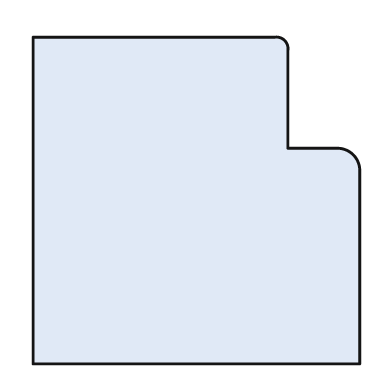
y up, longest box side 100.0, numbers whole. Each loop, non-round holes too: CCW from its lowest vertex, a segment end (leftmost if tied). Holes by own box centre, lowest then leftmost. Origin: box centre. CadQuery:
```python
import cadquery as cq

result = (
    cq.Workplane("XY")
    .moveTo(-50.0, -50.0)
    .lineTo(50.0, -50.0)
    .lineTo(50.0, 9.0)
    .threePointArc((48.0, 14.0), (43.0, 16.0))
    .lineTo(28.0, 16.0)
    .lineTo(28.0, 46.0)
    .threePointArc((27.0, 49.0), (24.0, 50.0))
    .lineTo(-50.0, 50.0)
    .close()
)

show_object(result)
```